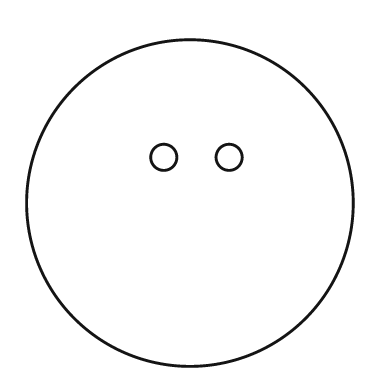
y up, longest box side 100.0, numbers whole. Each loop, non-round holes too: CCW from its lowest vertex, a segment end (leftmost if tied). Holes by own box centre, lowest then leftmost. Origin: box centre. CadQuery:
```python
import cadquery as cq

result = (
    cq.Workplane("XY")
    .moveTo(0.0, 0.0)
    .circle(50.0)
    .moveTo(-8.0, 14.0)
    .circle(4.0)
    .moveTo(12.0, 14.0)
    .circle(4.0)
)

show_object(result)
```